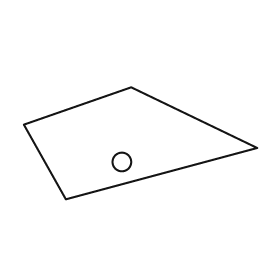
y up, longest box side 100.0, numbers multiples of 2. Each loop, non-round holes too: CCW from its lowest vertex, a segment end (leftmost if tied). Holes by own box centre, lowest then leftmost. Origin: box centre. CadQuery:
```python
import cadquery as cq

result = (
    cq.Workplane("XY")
    .moveTo(-32.0, -24.0)
    .lineTo(50.0, -2.0)
    .lineTo(-4.0, 24.0)
    .lineTo(-50.0, 8.0)
    .close()
    .moveTo(-8.0, -8.0)
    .circle(4.0)
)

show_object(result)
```